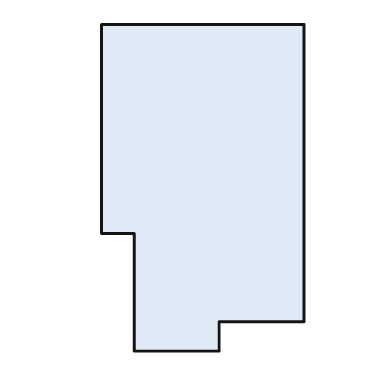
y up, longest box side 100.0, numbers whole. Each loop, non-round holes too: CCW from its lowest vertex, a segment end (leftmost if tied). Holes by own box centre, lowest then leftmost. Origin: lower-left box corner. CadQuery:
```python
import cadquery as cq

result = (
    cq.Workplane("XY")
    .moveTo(10.0, 0.0)
    .lineTo(36.0, 0.0)
    .lineTo(36.0, 9.0)
    .lineTo(62.0, 9.0)
    .lineTo(62.0, 100.0)
    .lineTo(0.0, 100.0)
    .lineTo(0.0, 36.0)
    .lineTo(10.0, 36.0)
    .close()
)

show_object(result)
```